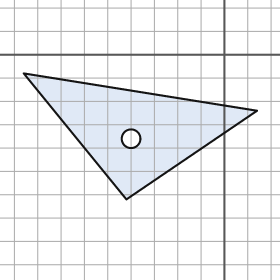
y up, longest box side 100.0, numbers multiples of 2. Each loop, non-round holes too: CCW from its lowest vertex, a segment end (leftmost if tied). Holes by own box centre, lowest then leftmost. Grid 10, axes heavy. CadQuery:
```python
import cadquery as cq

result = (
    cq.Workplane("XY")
    .moveTo(-42.0, -62.0)
    .lineTo(14.0, -24.0)
    .lineTo(-86.0, -8.0)
    .close()
    .moveTo(-40.0, -36.0)
    .circle(4.0)
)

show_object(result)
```